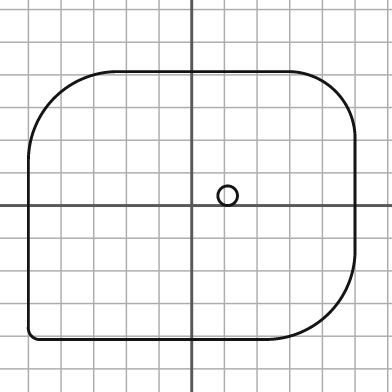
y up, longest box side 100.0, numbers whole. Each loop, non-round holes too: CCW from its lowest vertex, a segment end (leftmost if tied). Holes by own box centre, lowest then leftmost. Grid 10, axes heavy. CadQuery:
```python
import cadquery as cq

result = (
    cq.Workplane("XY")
    .moveTo(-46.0, -41.0)
    .lineTo(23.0, -41.0)
    .threePointArc((42.0, -33.0), (50.0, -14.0))
    .lineTo(50.0, 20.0)
    .threePointArc((44.0, 35.0), (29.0, 41.0))
    .lineTo(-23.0, 41.0)
    .threePointArc((-42.0, 33.0), (-50.0, 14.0))
    .lineTo(-50.0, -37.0)
    .threePointArc((-49.0, -40.0), (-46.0, -41.0))
    .close()
    .moveTo(11.0, 3.0)
    .circle(3.0)
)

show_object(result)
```